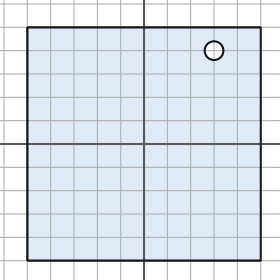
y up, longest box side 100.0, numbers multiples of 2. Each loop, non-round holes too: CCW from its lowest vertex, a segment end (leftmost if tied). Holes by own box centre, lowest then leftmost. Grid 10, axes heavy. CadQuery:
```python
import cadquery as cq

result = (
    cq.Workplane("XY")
    .moveTo(-50.0, -50.0)
    .lineTo(50.0, -50.0)
    .lineTo(50.0, 50.0)
    .lineTo(-50.0, 50.0)
    .close()
    .moveTo(30.0, 40.0)
    .circle(4.0)
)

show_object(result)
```